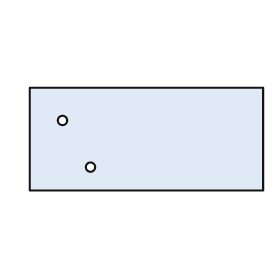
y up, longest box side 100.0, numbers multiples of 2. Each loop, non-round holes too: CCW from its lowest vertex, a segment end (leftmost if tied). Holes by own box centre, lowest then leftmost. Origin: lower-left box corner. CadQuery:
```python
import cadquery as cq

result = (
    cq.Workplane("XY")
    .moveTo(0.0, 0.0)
    .lineTo(100.0, 0.0)
    .lineTo(100.0, 44.0)
    .lineTo(0.0, 44.0)
    .close()
    .moveTo(26.0, 10.0)
    .circle(2.0)
    .moveTo(14.0, 30.0)
    .circle(2.0)
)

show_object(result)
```